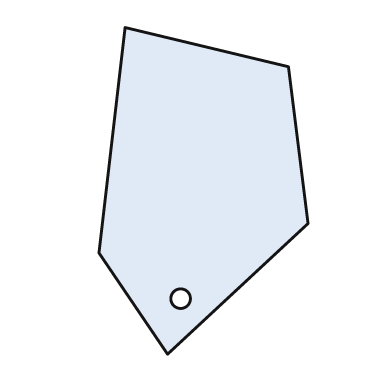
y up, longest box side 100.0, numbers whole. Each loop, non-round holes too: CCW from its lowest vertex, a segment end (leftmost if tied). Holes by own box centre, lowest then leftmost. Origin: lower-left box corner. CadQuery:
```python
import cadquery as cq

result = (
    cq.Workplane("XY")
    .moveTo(21.0, 0.0)
    .lineTo(64.0, 40.0)
    .lineTo(58.0, 88.0)
    .lineTo(8.0, 100.0)
    .lineTo(0.0, 31.0)
    .close()
    .moveTo(25.0, 17.0)
    .circle(3.0)
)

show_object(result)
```